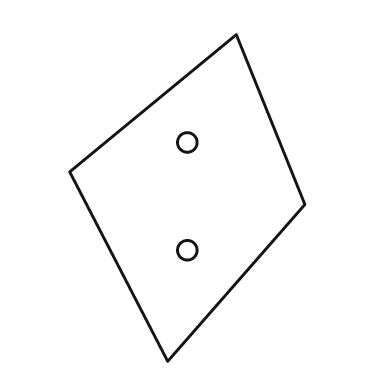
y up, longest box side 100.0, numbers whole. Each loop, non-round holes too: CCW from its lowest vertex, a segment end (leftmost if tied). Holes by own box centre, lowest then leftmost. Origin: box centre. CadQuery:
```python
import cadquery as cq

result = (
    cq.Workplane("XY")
    .moveTo(-6.0, -50.0)
    .lineTo(36.0, -2.0)
    .lineTo(15.0, 50.0)
    .lineTo(-36.0, 8.0)
    .close()
    .moveTo(0.0, -16.0)
    .circle(3.0)
    .moveTo(0.0, 17.0)
    .circle(3.0)
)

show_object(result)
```